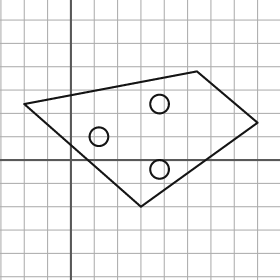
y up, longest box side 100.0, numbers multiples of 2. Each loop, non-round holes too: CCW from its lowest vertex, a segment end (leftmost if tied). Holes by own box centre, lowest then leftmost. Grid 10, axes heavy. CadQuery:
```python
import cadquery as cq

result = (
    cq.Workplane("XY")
    .moveTo(30.0, -20.0)
    .lineTo(80.0, 16.0)
    .lineTo(54.0, 38.0)
    .lineTo(-20.0, 24.0)
    .close()
    .moveTo(38.0, -4.0)
    .circle(4.0)
    .moveTo(12.0, 10.0)
    .circle(4.0)
    .moveTo(38.0, 24.0)
    .circle(4.0)
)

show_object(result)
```